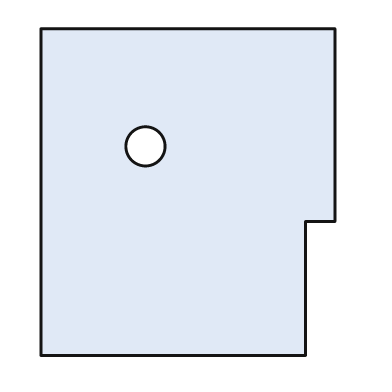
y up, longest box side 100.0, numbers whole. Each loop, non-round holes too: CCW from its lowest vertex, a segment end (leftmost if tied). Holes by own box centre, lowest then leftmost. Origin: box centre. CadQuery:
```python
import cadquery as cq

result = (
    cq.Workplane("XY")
    .moveTo(-45.0, -50.0)
    .lineTo(36.0, -50.0)
    .lineTo(36.0, -9.0)
    .lineTo(45.0, -9.0)
    .lineTo(45.0, 50.0)
    .lineTo(-45.0, 50.0)
    .close()
    .moveTo(-13.0, 14.0)
    .circle(6.0)
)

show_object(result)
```